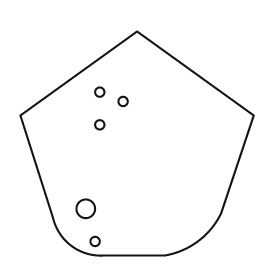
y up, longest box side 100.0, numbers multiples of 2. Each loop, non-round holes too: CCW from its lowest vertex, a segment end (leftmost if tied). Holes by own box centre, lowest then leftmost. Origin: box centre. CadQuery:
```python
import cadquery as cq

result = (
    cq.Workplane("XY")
    .moveTo(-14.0, -48.0)
    .lineTo(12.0, -48.0)
    .threePointArc((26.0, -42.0), (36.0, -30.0))
    .lineTo(50.0, 12.0)
    .lineTo(0.0, 48.0)
    .lineTo(-50.0, 12.0)
    .lineTo(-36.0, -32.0)
    .threePointArc((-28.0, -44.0), (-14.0, -48.0))
    .close()
    .moveTo(-18.0, -42.0)
    .circle(2.0)
    .moveTo(-22.0, -28.0)
    .circle(4.0)
    .moveTo(-16.0, 8.0)
    .circle(2.0)
    .moveTo(-6.0, 18.0)
    .circle(2.0)
    .moveTo(-16.0, 22.0)
    .circle(2.0)
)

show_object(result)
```